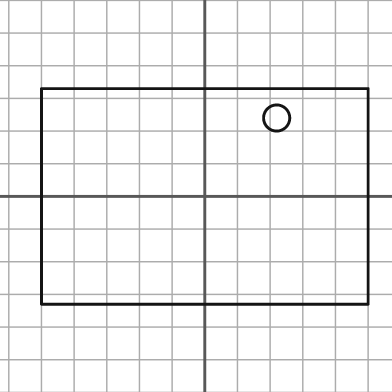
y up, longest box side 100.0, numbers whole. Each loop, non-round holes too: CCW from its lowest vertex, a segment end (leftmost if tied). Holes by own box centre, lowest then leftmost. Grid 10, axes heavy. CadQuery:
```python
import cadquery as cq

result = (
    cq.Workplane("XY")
    .moveTo(-50.0, -33.0)
    .lineTo(50.0, -33.0)
    .lineTo(50.0, 33.0)
    .lineTo(-50.0, 33.0)
    .close()
    .moveTo(22.0, 24.0)
    .circle(4.0)
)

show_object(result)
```